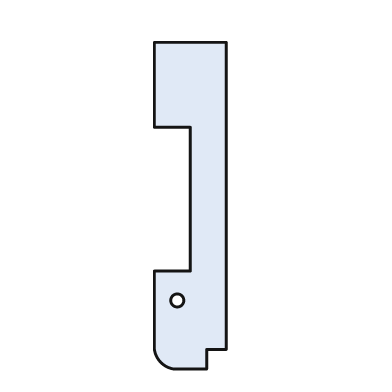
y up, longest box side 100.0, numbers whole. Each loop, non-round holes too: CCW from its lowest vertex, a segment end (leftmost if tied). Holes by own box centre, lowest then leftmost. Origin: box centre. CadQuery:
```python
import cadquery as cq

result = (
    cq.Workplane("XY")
    .moveTo(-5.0, -50.0)
    .lineTo(5.0, -50.0)
    .lineTo(5.0, -44.0)
    .lineTo(11.0, -44.0)
    .lineTo(11.0, 50.0)
    .lineTo(-11.0, 50.0)
    .lineTo(-11.0, 24.0)
    .lineTo(0.0, 24.0)
    .lineTo(0.0, -20.0)
    .lineTo(-11.0, -20.0)
    .lineTo(-11.0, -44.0)
    .threePointArc((-9.0, -48.0), (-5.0, -50.0))
    .close()
    .moveTo(-4.0, -29.0)
    .circle(2.0)
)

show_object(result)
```